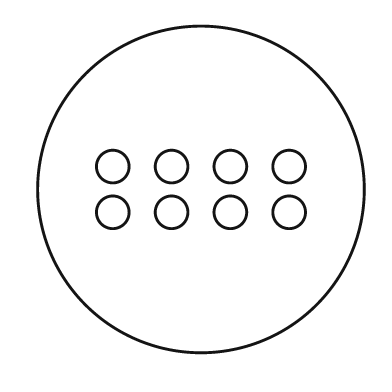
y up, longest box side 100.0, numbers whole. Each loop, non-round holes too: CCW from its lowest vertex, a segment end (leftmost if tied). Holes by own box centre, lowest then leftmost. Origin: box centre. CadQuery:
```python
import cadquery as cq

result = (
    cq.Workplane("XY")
    .moveTo(0.0, 0.0)
    .circle(50.0)
    .moveTo(-27.0, -7.0)
    .circle(5.0)
    .moveTo(-9.0, -7.0)
    .circle(5.0)
    .moveTo(9.0, -7.0)
    .circle(5.0)
    .moveTo(27.0, -7.0)
    .circle(5.0)
    .moveTo(-27.0, 7.0)
    .circle(5.0)
    .moveTo(-9.0, 7.0)
    .circle(5.0)
    .moveTo(9.0, 7.0)
    .circle(5.0)
    .moveTo(27.0, 7.0)
    .circle(5.0)
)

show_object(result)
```